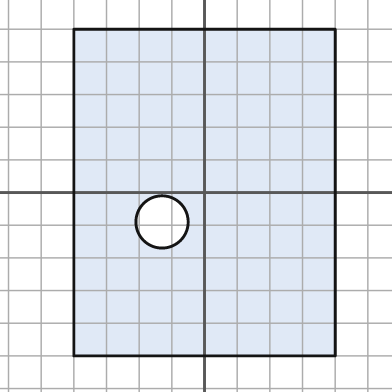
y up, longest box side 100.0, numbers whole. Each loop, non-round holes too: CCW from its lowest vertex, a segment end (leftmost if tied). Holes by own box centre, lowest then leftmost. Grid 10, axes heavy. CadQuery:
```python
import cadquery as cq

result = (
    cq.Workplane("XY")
    .moveTo(-40.0, -50.0)
    .lineTo(40.0, -50.0)
    .lineTo(40.0, 50.0)
    .lineTo(-40.0, 50.0)
    .close()
    .moveTo(-13.0, -9.0)
    .circle(8.0)
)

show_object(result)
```